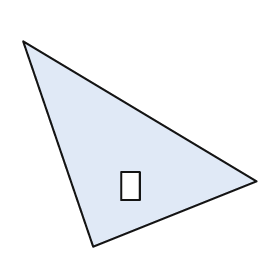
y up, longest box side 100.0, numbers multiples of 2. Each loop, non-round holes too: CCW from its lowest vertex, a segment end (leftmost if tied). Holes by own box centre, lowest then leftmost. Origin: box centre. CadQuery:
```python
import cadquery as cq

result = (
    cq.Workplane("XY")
    .moveTo(-20.0, -44.0)
    .lineTo(50.0, -16.0)
    .lineTo(-50.0, 44.0)
    .close()
    .moveTo(-8.0, -24.0)
    .lineTo(0.0, -24.0)
    .lineTo(0.0, -12.0)
    .lineTo(-8.0, -12.0)
    .close()
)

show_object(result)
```